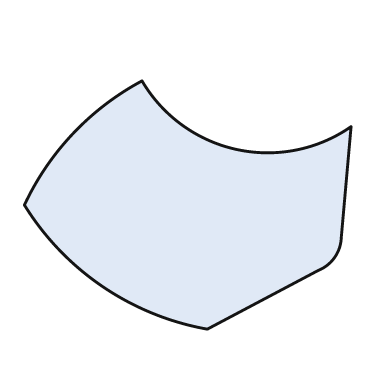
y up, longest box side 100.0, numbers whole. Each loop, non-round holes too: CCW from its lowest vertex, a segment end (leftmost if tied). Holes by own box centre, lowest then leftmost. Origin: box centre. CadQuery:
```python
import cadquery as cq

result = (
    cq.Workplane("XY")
    .moveTo(6.0, -38.0)
    .lineTo(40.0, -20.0)
    .threePointArc((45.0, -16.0), (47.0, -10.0))
    .lineTo(50.0, 24.0)
    .threePointArc((15.0, 17.0), (-14.0, 38.0))
    .threePointArc((-35.0, 22.0), (-50.0, 0.0))
    .threePointArc((-26.0, -25.0), (6.0, -38.0))
    .close()
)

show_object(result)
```